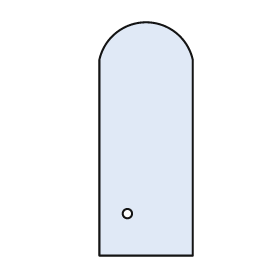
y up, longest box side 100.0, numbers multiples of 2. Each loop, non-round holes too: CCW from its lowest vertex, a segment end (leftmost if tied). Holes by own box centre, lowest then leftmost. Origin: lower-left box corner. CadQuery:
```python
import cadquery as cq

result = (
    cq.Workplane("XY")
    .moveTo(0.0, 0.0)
    .lineTo(40.0, 0.0)
    .lineTo(40.0, 84.0)
    .threePointArc((20.0, 100.0), (0.0, 84.0))
    .close()
    .moveTo(12.0, 18.0)
    .circle(2.0)
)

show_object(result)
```